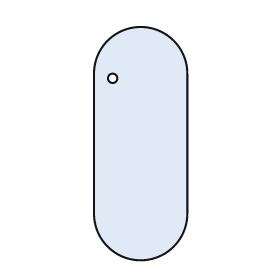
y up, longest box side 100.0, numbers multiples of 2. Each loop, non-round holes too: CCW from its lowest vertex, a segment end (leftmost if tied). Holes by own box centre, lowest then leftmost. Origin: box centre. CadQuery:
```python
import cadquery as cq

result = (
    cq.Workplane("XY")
    .moveTo(-20.0, -30.0)
    .threePointArc((0.0, -50.0), (20.0, -30.0))
    .lineTo(20.0, 30.0)
    .threePointArc((0.0, 50.0), (-20.0, 30.0))
    .close()
    .moveTo(-12.0, 28.0)
    .circle(2.0)
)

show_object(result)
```